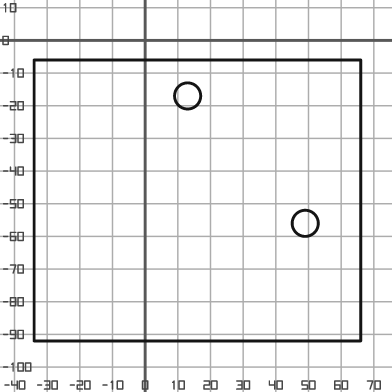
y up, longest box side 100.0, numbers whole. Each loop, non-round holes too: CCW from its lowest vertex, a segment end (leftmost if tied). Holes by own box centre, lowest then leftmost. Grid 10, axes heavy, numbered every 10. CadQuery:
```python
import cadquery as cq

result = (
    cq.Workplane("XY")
    .moveTo(-34.0, -92.0)
    .lineTo(66.0, -92.0)
    .lineTo(66.0, -6.0)
    .lineTo(-34.0, -6.0)
    .close()
    .moveTo(49.0, -56.0)
    .circle(4.0)
    .moveTo(13.0, -17.0)
    .circle(4.0)
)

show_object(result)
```